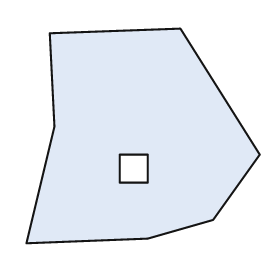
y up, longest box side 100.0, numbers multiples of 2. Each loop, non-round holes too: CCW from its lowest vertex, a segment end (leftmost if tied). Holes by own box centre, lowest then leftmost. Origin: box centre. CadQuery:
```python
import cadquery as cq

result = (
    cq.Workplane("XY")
    .moveTo(-50.0, -46.0)
    .lineTo(2.0, -44.0)
    .lineTo(30.0, -36.0)
    .lineTo(50.0, -8.0)
    .lineTo(16.0, 46.0)
    .lineTo(-40.0, 44.0)
    .lineTo(-38.0, 4.0)
    .close()
    .moveTo(-10.0, -20.0)
    .lineTo(2.0, -20.0)
    .lineTo(2.0, -8.0)
    .lineTo(-10.0, -8.0)
    .close()
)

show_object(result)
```